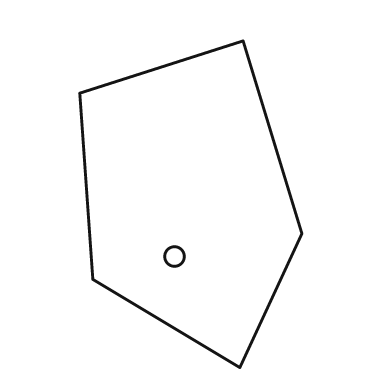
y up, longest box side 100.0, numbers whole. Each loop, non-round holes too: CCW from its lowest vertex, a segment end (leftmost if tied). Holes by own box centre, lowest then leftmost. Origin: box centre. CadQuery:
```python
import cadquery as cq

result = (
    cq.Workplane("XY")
    .moveTo(15.0, -50.0)
    .lineTo(34.0, -9.0)
    .lineTo(16.0, 50.0)
    .lineTo(-34.0, 34.0)
    .lineTo(-30.0, -23.0)
    .close()
    .moveTo(-5.0, -16.0)
    .circle(3.0)
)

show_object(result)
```